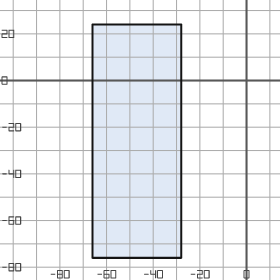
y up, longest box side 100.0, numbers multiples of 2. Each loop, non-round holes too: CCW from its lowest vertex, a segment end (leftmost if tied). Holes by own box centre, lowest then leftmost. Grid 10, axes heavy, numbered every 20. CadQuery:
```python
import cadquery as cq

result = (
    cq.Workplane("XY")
    .moveTo(-66.0, -76.0)
    .lineTo(-28.0, -76.0)
    .lineTo(-28.0, 24.0)
    .lineTo(-66.0, 24.0)
    .close()
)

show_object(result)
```